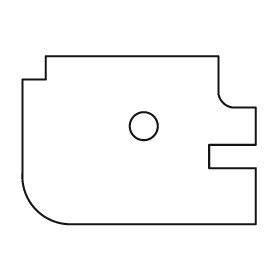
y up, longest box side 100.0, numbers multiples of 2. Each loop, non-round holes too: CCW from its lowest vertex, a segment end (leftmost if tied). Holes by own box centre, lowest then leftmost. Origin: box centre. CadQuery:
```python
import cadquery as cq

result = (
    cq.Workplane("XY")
    .moveTo(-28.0, -36.0)
    .lineTo(50.0, -36.0)
    .lineTo(50.0, -12.0)
    .lineTo(30.0, -12.0)
    .lineTo(30.0, -2.0)
    .lineTo(50.0, -2.0)
    .lineTo(50.0, 14.0)
    .lineTo(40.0, 14.0)
    .threePointArc((36.0, 16.0), (34.0, 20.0))
    .lineTo(34.0, 36.0)
    .lineTo(-40.0, 36.0)
    .lineTo(-40.0, 26.0)
    .lineTo(-50.0, 26.0)
    .lineTo(-50.0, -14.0)
    .threePointArc((-44.0, -30.0), (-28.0, -36.0))
    .close()
    .moveTo(2.0, 6.0)
    .circle(6.0)
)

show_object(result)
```